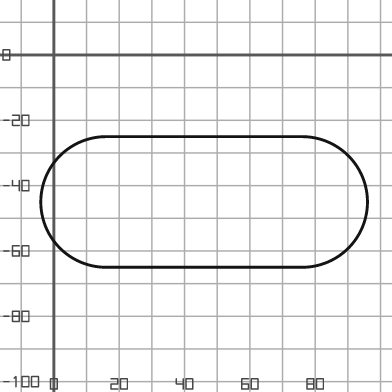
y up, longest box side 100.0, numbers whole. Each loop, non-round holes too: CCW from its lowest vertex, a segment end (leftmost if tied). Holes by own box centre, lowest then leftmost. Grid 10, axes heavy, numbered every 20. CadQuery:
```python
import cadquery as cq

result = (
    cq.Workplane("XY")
    .moveTo(16.0, -65.0)
    .lineTo(76.0, -65.0)
    .threePointArc((96.0, -45.0), (76.0, -25.0))
    .lineTo(16.0, -25.0)
    .threePointArc((-4.0, -45.0), (16.0, -65.0))
    .close()
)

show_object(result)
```